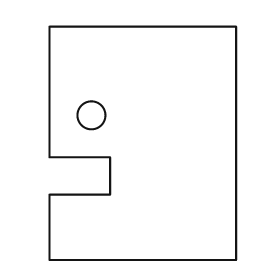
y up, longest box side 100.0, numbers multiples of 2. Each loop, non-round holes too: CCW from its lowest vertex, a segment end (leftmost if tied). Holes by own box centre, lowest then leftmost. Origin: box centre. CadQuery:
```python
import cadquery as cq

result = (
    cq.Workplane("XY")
    .moveTo(-40.0, -50.0)
    .lineTo(40.0, -50.0)
    .lineTo(40.0, 50.0)
    .lineTo(-40.0, 50.0)
    .lineTo(-40.0, -6.0)
    .lineTo(-14.0, -6.0)
    .lineTo(-14.0, -22.0)
    .lineTo(-40.0, -22.0)
    .close()
    .moveTo(-22.0, 12.0)
    .circle(6.0)
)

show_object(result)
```